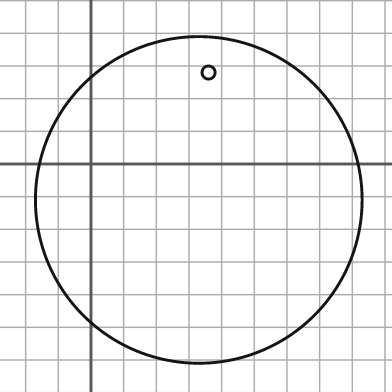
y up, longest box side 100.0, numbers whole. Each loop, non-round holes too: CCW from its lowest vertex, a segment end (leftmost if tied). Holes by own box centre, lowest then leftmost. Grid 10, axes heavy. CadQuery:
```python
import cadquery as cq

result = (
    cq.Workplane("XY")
    .moveTo(33.0, -11.0)
    .circle(50.0)
    .moveTo(36.0, 28.0)
    .circle(2.0)
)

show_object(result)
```